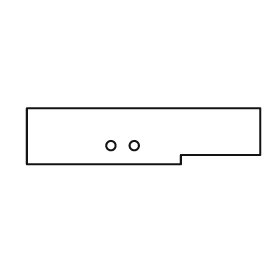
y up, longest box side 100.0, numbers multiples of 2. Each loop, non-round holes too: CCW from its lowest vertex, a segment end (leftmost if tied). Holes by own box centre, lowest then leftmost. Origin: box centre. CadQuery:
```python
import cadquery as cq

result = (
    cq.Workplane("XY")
    .moveTo(-50.0, -12.0)
    .lineTo(16.0, -12.0)
    .lineTo(16.0, -8.0)
    .lineTo(50.0, -8.0)
    .lineTo(50.0, 12.0)
    .lineTo(-50.0, 12.0)
    .close()
    .moveTo(-14.0, -4.0)
    .circle(2.0)
    .moveTo(-4.0, -4.0)
    .circle(2.0)
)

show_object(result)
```